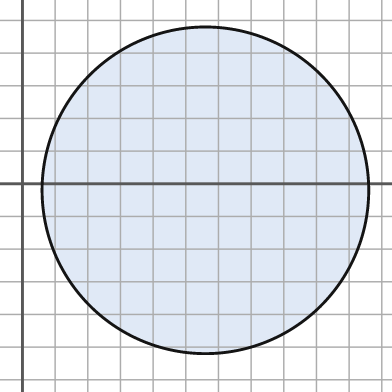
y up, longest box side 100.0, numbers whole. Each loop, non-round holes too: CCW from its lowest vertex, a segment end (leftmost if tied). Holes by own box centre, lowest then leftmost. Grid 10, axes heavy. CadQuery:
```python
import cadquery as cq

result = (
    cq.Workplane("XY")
    .moveTo(56.0, -2.0)
    .circle(50.0)
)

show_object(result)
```